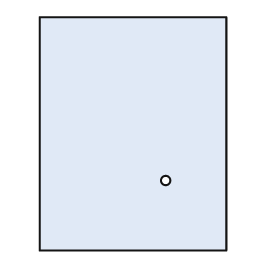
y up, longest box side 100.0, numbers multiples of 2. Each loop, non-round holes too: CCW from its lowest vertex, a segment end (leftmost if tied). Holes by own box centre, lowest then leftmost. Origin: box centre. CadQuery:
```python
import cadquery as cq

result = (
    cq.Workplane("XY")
    .moveTo(-40.0, -50.0)
    .lineTo(40.0, -50.0)
    .lineTo(40.0, 50.0)
    .lineTo(-40.0, 50.0)
    .close()
    .moveTo(14.0, -20.0)
    .circle(2.0)
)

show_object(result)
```